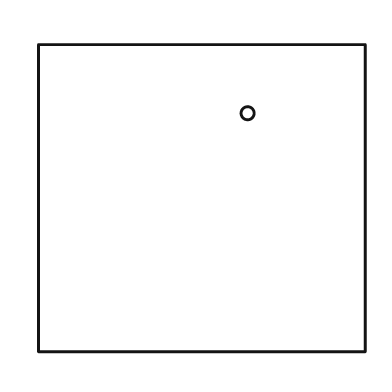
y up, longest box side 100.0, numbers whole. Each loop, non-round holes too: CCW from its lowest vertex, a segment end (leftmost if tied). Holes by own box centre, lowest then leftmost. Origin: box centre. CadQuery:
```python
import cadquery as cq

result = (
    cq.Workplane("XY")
    .moveTo(-50.0, -47.0)
    .lineTo(50.0, -47.0)
    .lineTo(50.0, 47.0)
    .lineTo(-50.0, 47.0)
    .close()
    .moveTo(14.0, 26.0)
    .circle(2.0)
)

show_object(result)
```